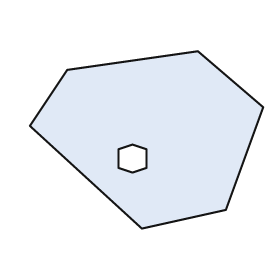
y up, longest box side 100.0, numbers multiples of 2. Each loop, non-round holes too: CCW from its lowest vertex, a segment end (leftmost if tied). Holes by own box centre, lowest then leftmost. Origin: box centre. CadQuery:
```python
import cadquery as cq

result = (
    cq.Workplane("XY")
    .moveTo(-2.0, -38.0)
    .lineTo(34.0, -30.0)
    .lineTo(50.0, 14.0)
    .lineTo(22.0, 38.0)
    .lineTo(-34.0, 30.0)
    .lineTo(-50.0, 6.0)
    .close()
    .moveTo(-6.0, -14.0)
    .lineTo(0.0, -12.0)
    .lineTo(0.0, -4.0)
    .lineTo(-6.0, -2.0)
    .lineTo(-12.0, -4.0)
    .lineTo(-12.0, -12.0)
    .close()
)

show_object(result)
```